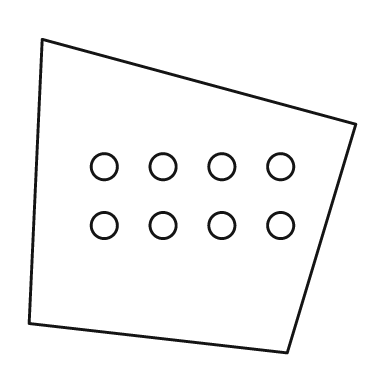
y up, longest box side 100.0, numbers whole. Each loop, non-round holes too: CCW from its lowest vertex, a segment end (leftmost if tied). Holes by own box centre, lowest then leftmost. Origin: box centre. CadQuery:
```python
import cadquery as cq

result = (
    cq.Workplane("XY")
    .moveTo(29.0, -48.0)
    .lineTo(50.0, 22.0)
    .lineTo(-46.0, 48.0)
    .lineTo(-50.0, -39.0)
    .close()
    .moveTo(-27.0, -9.0)
    .circle(4.0)
    .moveTo(-9.0, -9.0)
    .circle(4.0)
    .moveTo(9.0, -9.0)
    .circle(4.0)
    .moveTo(27.0, -9.0)
    .circle(4.0)
    .moveTo(-27.0, 9.0)
    .circle(4.0)
    .moveTo(-9.0, 9.0)
    .circle(4.0)
    .moveTo(9.0, 9.0)
    .circle(4.0)
    .moveTo(27.0, 9.0)
    .circle(4.0)
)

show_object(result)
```